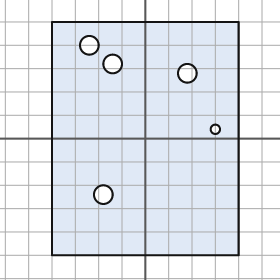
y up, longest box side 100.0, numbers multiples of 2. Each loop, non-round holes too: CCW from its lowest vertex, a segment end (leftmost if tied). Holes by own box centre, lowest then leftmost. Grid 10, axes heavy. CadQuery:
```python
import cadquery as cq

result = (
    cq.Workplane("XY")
    .moveTo(-40.0, -50.0)
    .lineTo(40.0, -50.0)
    .lineTo(40.0, 50.0)
    .lineTo(-40.0, 50.0)
    .close()
    .moveTo(-18.0, -24.0)
    .circle(4.0)
    .moveTo(30.0, 4.0)
    .circle(2.0)
    .moveTo(18.0, 28.0)
    .circle(4.0)
    .moveTo(-14.0, 32.0)
    .circle(4.0)
    .moveTo(-24.0, 40.0)
    .circle(4.0)
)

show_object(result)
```